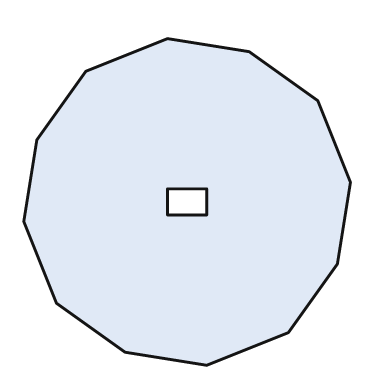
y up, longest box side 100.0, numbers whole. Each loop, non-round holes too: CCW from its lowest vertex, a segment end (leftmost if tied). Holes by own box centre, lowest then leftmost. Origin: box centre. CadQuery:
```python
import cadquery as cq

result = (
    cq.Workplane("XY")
    .moveTo(6.0, -50.0)
    .lineTo(31.0, -40.0)
    .lineTo(46.0, -19.0)
    .lineTo(50.0, 6.0)
    .lineTo(40.0, 31.0)
    .lineTo(19.0, 46.0)
    .lineTo(-6.0, 50.0)
    .lineTo(-31.0, 40.0)
    .lineTo(-46.0, 19.0)
    .lineTo(-50.0, -6.0)
    .lineTo(-40.0, -31.0)
    .lineTo(-19.0, -46.0)
    .close()
    .moveTo(-6.0, -4.0)
    .lineTo(6.0, -4.0)
    .lineTo(6.0, 4.0)
    .lineTo(-6.0, 4.0)
    .close()
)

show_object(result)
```